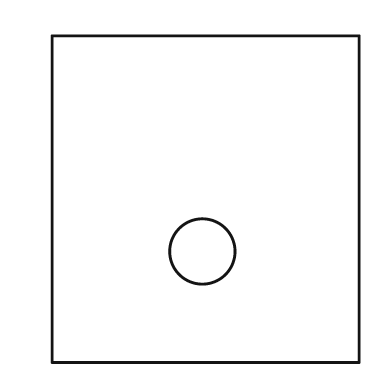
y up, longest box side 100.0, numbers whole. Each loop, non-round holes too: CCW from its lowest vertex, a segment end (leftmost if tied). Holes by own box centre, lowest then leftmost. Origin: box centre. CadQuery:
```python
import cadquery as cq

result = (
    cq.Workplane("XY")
    .moveTo(-47.0, -50.0)
    .lineTo(47.0, -50.0)
    .lineTo(47.0, 50.0)
    .lineTo(-47.0, 50.0)
    .close()
    .moveTo(-1.0, -16.0)
    .circle(10.0)
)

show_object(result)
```